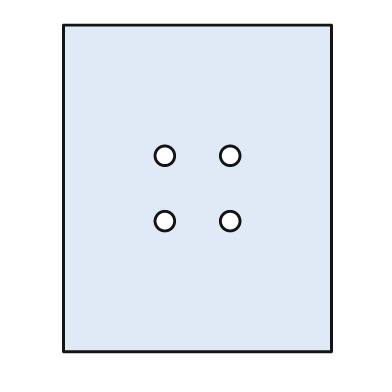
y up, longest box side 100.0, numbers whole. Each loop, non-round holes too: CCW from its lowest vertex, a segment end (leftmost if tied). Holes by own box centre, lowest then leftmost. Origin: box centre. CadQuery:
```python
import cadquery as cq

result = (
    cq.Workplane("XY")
    .moveTo(-41.0, -50.0)
    .lineTo(41.0, -50.0)
    .lineTo(41.0, 50.0)
    .lineTo(-41.0, 50.0)
    .close()
    .moveTo(-10.0, -10.0)
    .circle(3.0)
    .moveTo(10.0, -10.0)
    .circle(3.0)
    .moveTo(-10.0, 10.0)
    .circle(3.0)
    .moveTo(10.0, 10.0)
    .circle(3.0)
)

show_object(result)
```